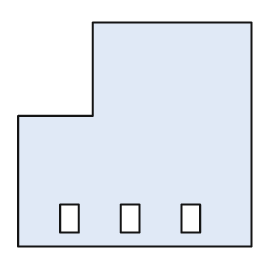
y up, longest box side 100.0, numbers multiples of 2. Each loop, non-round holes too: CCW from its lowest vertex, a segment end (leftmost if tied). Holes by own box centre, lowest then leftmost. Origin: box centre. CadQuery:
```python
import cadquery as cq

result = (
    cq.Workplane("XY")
    .moveTo(-50.0, -48.0)
    .lineTo(50.0, -48.0)
    .lineTo(50.0, 48.0)
    .lineTo(-18.0, 48.0)
    .lineTo(-18.0, 8.0)
    .lineTo(-50.0, 8.0)
    .close()
    .moveTo(-32.0, -42.0)
    .lineTo(-24.0, -42.0)
    .lineTo(-24.0, -30.0)
    .lineTo(-32.0, -30.0)
    .close()
    .moveTo(-6.0, -42.0)
    .lineTo(2.0, -42.0)
    .lineTo(2.0, -30.0)
    .lineTo(-6.0, -30.0)
    .close()
    .moveTo(20.0, -42.0)
    .lineTo(28.0, -42.0)
    .lineTo(28.0, -30.0)
    .lineTo(20.0, -30.0)
    .close()
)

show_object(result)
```